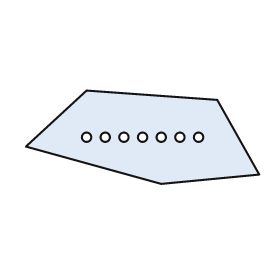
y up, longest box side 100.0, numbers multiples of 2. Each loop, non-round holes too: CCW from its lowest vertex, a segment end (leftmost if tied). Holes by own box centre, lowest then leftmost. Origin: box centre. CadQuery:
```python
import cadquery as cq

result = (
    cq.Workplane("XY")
    .moveTo(8.0, -20.0)
    .lineTo(50.0, -16.0)
    .lineTo(32.0, 16.0)
    .lineTo(-24.0, 20.0)
    .lineTo(-50.0, -4.0)
    .close()
    .moveTo(-24.0, 0.0)
    .circle(2.0)
    .moveTo(-16.0, 0.0)
    .circle(2.0)
    .moveTo(-8.0, 0.0)
    .circle(2.0)
    .moveTo(0.0, 0.0)
    .circle(2.0)
    .moveTo(8.0, 0.0)
    .circle(2.0)
    .moveTo(16.0, 0.0)
    .circle(2.0)
    .moveTo(24.0, 0.0)
    .circle(2.0)
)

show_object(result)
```